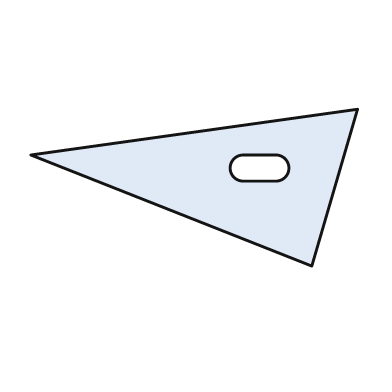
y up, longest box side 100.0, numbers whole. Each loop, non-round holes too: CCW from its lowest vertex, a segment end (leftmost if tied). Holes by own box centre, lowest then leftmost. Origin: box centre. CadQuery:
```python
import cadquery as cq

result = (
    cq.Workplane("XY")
    .moveTo(36.0, -24.0)
    .lineTo(50.0, 24.0)
    .lineTo(-50.0, 10.0)
    .close()
    .moveTo(15.0, 2.0)
    .lineTo(25.0, 2.0)
    .threePointArc((29.0, 6.0), (25.0, 10.0))
    .lineTo(15.0, 10.0)
    .threePointArc((11.0, 6.0), (15.0, 2.0))
    .close()
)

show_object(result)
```